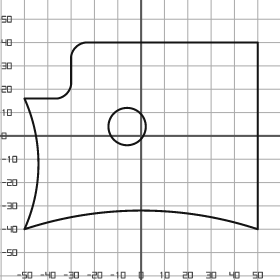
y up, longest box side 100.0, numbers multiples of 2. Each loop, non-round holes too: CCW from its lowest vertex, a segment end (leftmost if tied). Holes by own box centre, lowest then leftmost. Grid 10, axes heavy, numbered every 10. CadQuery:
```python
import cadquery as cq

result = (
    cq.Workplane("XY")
    .moveTo(-50.0, -40.0)
    .threePointArc((0.0, -32.0), (50.0, -40.0))
    .lineTo(50.0, 40.0)
    .lineTo(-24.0, 40.0)
    .threePointArc((-28.0, 38.0), (-30.0, 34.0))
    .lineTo(-30.0, 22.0)
    .threePointArc((-32.0, 18.0), (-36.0, 16.0))
    .lineTo(-50.0, 16.0)
    .threePointArc((-44.0, -12.0), (-50.0, -40.0))
    .close()
    .moveTo(-6.0, 4.0)
    .circle(8.0)
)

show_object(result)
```